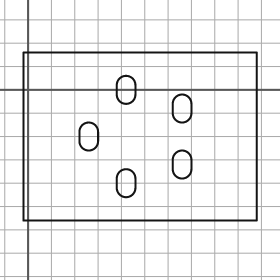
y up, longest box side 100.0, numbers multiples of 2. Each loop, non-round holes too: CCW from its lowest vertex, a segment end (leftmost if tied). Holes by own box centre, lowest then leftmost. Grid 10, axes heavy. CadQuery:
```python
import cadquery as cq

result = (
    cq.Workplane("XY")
    .moveTo(-2.0, -56.0)
    .lineTo(98.0, -56.0)
    .lineTo(98.0, 16.0)
    .lineTo(-2.0, 16.0)
    .close()
    .moveTo(38.0, -42.0)
    .threePointArc((42.0, -46.0), (46.0, -42.0))
    .lineTo(46.0, -38.0)
    .threePointArc((42.0, -34.0), (38.0, -38.0))
    .close()
    .moveTo(62.0, -34.0)
    .threePointArc((66.0, -38.0), (70.0, -34.0))
    .lineTo(70.0, -30.0)
    .threePointArc((66.0, -26.0), (62.0, -30.0))
    .close()
    .moveTo(22.0, -22.0)
    .threePointArc((26.0, -26.0), (30.0, -22.0))
    .lineTo(30.0, -18.0)
    .threePointArc((26.0, -14.0), (22.0, -18.0))
    .close()
    .moveTo(62.0, -10.0)
    .threePointArc((66.0, -14.0), (70.0, -10.0))
    .lineTo(70.0, -6.0)
    .threePointArc((66.0, -2.0), (62.0, -6.0))
    .close()
    .moveTo(38.0, -2.0)
    .threePointArc((42.0, -6.0), (46.0, -2.0))
    .lineTo(46.0, 2.0)
    .threePointArc((42.0, 6.0), (38.0, 2.0))
    .close()
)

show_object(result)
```